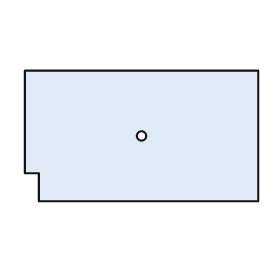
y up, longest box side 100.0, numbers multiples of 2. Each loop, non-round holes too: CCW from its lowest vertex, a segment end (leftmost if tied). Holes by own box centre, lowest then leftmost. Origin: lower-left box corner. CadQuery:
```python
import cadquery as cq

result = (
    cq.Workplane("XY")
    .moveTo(6.0, 0.0)
    .lineTo(100.0, 0.0)
    .lineTo(100.0, 56.0)
    .lineTo(0.0, 56.0)
    .lineTo(0.0, 12.0)
    .lineTo(6.0, 12.0)
    .close()
    .moveTo(50.0, 28.0)
    .circle(2.0)
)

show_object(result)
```